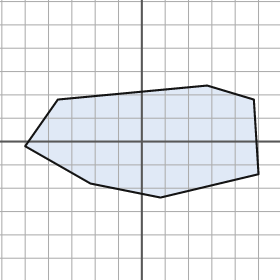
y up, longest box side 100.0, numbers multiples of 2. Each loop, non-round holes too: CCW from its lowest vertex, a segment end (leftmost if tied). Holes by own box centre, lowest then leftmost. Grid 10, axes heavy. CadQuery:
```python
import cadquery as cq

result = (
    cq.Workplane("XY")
    .moveTo(8.0, -24.0)
    .lineTo(50.0, -14.0)
    .lineTo(48.0, 18.0)
    .lineTo(28.0, 24.0)
    .lineTo(-36.0, 18.0)
    .lineTo(-50.0, -2.0)
    .lineTo(-22.0, -18.0)
    .close()
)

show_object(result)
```